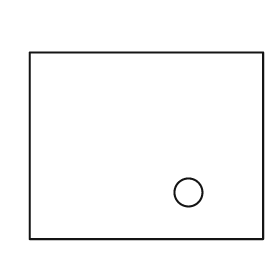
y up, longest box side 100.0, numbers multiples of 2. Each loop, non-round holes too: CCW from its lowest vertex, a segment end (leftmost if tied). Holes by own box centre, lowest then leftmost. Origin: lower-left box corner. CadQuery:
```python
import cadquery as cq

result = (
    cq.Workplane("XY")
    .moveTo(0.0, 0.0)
    .lineTo(100.0, 0.0)
    .lineTo(100.0, 80.0)
    .lineTo(0.0, 80.0)
    .close()
    .moveTo(68.0, 20.0)
    .circle(6.0)
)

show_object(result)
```